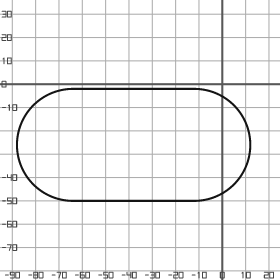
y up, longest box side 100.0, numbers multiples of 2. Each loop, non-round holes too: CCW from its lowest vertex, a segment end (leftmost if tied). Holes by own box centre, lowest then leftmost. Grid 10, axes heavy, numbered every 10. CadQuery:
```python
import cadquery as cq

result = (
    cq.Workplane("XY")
    .moveTo(-64.0, -50.0)
    .lineTo(-12.0, -50.0)
    .threePointArc((12.0, -26.0), (-12.0, -2.0))
    .lineTo(-64.0, -2.0)
    .threePointArc((-88.0, -26.0), (-64.0, -50.0))
    .close()
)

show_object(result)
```